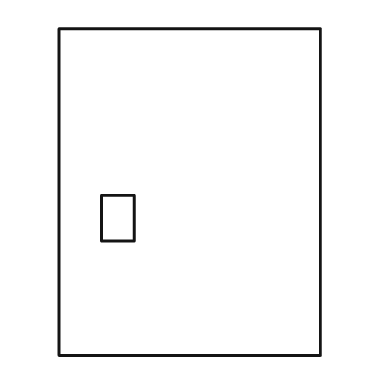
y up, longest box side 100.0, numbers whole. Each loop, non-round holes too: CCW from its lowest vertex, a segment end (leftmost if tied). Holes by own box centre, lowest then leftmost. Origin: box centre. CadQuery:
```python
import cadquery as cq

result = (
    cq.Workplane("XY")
    .moveTo(-40.0, -50.0)
    .lineTo(40.0, -50.0)
    .lineTo(40.0, 50.0)
    .lineTo(-40.0, 50.0)
    .close()
    .moveTo(-27.0, -15.0)
    .lineTo(-17.0, -15.0)
    .lineTo(-17.0, -1.0)
    .lineTo(-27.0, -1.0)
    .close()
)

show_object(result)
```